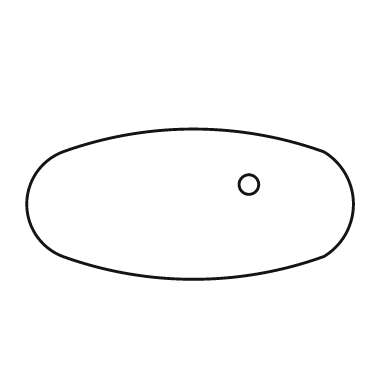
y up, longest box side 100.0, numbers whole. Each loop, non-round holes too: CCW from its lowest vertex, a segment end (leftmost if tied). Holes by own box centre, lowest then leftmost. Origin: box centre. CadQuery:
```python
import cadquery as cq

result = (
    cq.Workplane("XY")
    .moveTo(-39.0, -16.0)
    .threePointArc((1.0, -23.0), (41.0, -16.0))
    .threePointArc((50.0, 0.0), (41.0, 16.0))
    .threePointArc((1.0, 23.0), (-39.0, 16.0))
    .threePointArc((-50.0, 0.0), (-39.0, -16.0))
    .close()
    .moveTo(18.0, 6.0)
    .circle(3.0)
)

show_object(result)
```